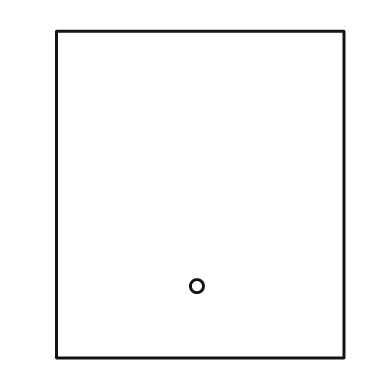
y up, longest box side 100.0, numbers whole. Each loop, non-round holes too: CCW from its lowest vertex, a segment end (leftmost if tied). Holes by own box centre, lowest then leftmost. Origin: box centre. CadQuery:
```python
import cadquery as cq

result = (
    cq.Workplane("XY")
    .moveTo(-44.0, -50.0)
    .lineTo(44.0, -50.0)
    .lineTo(44.0, 50.0)
    .lineTo(-44.0, 50.0)
    .close()
    .moveTo(-1.0, -28.0)
    .circle(2.0)
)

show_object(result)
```